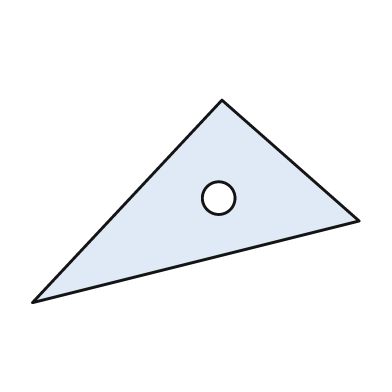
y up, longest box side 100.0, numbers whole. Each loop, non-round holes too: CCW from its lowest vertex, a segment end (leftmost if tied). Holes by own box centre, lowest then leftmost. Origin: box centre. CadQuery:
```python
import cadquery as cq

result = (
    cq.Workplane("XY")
    .moveTo(-50.0, -31.0)
    .lineTo(50.0, -6.0)
    .lineTo(8.0, 31.0)
    .close()
    .moveTo(7.0, 1.0)
    .circle(5.0)
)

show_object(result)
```